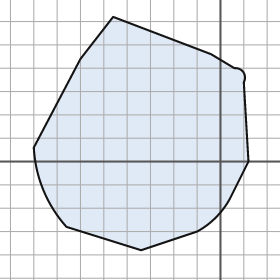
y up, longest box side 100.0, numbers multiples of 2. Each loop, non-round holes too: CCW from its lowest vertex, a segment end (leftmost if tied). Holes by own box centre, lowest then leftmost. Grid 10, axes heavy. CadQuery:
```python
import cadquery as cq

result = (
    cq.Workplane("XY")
    .moveTo(-34.0, -38.0)
    .lineTo(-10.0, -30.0)
    .threePointArc((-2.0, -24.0), (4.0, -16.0))
    .lineTo(12.0, 0.0)
    .lineTo(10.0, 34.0)
    .threePointArc((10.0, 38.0), (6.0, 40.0))
    .lineTo(-4.0, 46.0)
    .lineTo(-46.0, 62.0)
    .lineTo(-60.0, 44.0)
    .lineTo(-80.0, 6.0)
    .threePointArc((-76.0, -12.0), (-66.0, -28.0))
    .close()
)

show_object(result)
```